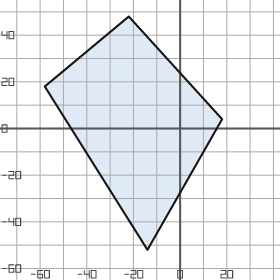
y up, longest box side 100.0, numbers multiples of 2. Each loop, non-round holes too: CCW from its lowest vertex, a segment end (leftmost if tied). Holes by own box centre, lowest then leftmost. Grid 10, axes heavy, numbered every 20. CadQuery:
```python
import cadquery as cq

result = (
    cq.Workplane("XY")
    .moveTo(-14.0, -52.0)
    .lineTo(18.0, 4.0)
    .lineTo(-22.0, 48.0)
    .lineTo(-58.0, 18.0)
    .close()
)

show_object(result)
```